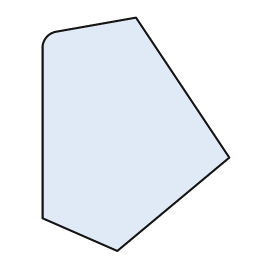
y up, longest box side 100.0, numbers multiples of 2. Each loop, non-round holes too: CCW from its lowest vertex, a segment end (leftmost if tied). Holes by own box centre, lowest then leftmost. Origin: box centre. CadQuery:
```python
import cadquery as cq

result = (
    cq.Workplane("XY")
    .moveTo(-8.0, -50.0)
    .lineTo(40.0, -10.0)
    .lineTo(0.0, 50.0)
    .lineTo(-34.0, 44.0)
    .threePointArc((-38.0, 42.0), (-40.0, 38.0))
    .lineTo(-40.0, -36.0)
    .close()
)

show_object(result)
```